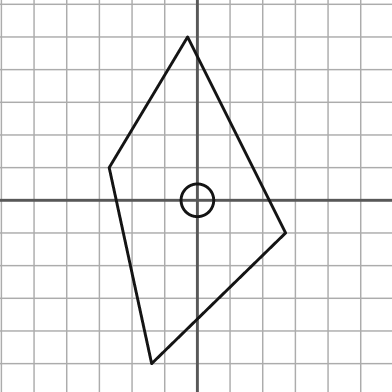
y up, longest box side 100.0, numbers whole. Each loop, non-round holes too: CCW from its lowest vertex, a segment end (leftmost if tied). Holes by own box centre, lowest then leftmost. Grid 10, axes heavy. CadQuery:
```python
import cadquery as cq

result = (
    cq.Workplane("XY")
    .moveTo(-14.0, -50.0)
    .lineTo(27.0, -10.0)
    .lineTo(-3.0, 50.0)
    .lineTo(-27.0, 10.0)
    .close()
    .moveTo(0.0, 0.0)
    .circle(5.0)
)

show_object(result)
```